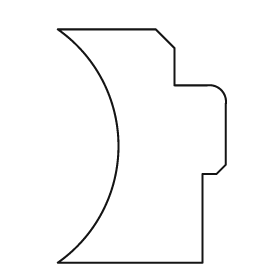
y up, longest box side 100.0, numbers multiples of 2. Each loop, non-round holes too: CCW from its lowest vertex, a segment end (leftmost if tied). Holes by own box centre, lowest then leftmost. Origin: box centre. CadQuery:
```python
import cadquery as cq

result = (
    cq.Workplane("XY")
    .moveTo(-36.0, -50.0)
    .lineTo(26.0, -50.0)
    .lineTo(26.0, -12.0)
    .lineTo(32.0, -12.0)
    .lineTo(36.0, -8.0)
    .lineTo(36.0, 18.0)
    .threePointArc((34.0, 24.0), (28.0, 26.0))
    .lineTo(14.0, 26.0)
    .lineTo(14.0, 42.0)
    .lineTo(6.0, 50.0)
    .lineTo(-36.0, 50.0)
    .threePointArc((-10.0, 0.0), (-36.0, -50.0))
    .close()
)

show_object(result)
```